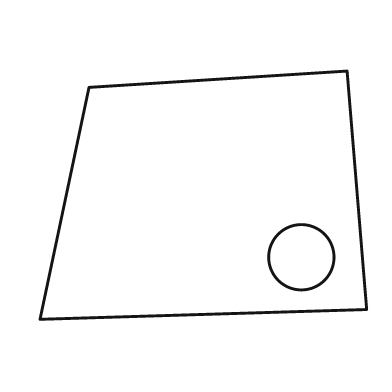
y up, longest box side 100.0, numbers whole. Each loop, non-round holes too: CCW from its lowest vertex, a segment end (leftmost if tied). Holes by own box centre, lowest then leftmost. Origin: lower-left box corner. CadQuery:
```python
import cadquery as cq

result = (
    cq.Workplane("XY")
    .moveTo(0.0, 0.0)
    .lineTo(100.0, 3.0)
    .lineTo(94.0, 76.0)
    .lineTo(15.0, 71.0)
    .close()
    .moveTo(80.0, 19.0)
    .circle(10.0)
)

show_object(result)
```